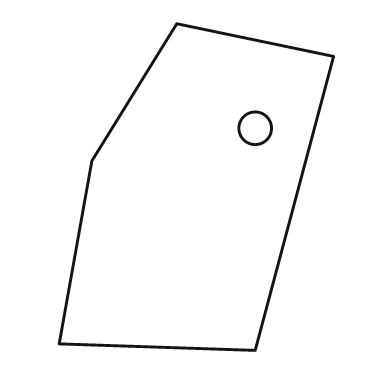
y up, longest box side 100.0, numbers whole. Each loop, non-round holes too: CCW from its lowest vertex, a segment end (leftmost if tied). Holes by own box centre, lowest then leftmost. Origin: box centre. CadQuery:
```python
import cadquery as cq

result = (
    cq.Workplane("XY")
    .moveTo(18.0, -50.0)
    .lineTo(42.0, 40.0)
    .lineTo(-6.0, 50.0)
    .lineTo(-32.0, 8.0)
    .lineTo(-42.0, -48.0)
    .close()
    .moveTo(18.0, 18.0)
    .circle(5.0)
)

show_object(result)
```